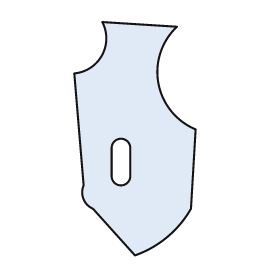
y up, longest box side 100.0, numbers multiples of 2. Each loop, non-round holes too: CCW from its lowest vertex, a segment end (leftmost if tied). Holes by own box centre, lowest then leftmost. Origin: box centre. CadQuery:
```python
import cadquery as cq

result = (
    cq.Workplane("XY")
    .moveTo(0.0, -50.0)
    .threePointArc((14.0, -42.0), (24.0, -30.0))
    .lineTo(26.0, 4.0)
    .threePointArc((10.0, 24.0), (18.0, 48.0))
    .lineTo(-14.0, 50.0)
    .threePointArc((-14.0, 36.0), (-26.0, 28.0))
    .lineTo(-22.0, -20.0)
    .threePointArc((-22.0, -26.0), (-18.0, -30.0))
    .close()
    .moveTo(-10.0, -16.0)
    .threePointArc((-6.0, -20.0), (-2.0, -16.0))
    .lineTo(-2.0, -4.0)
    .threePointArc((-6.0, 0.0), (-10.0, -4.0))
    .close()
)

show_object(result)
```